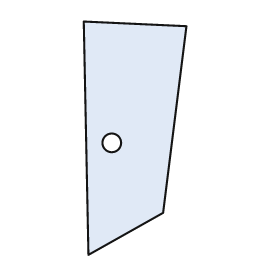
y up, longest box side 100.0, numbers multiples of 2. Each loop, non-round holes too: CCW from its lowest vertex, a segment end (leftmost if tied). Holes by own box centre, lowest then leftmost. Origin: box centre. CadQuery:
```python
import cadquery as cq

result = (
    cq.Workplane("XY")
    .moveTo(-20.0, -50.0)
    .lineTo(12.0, -32.0)
    .lineTo(22.0, 48.0)
    .lineTo(-22.0, 50.0)
    .close()
    .moveTo(-10.0, -2.0)
    .circle(4.0)
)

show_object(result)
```